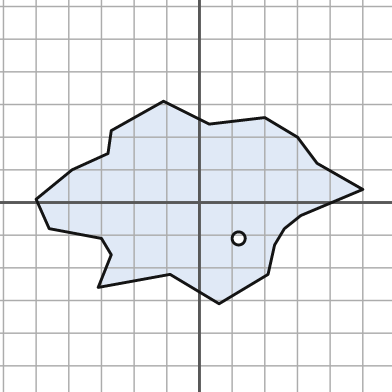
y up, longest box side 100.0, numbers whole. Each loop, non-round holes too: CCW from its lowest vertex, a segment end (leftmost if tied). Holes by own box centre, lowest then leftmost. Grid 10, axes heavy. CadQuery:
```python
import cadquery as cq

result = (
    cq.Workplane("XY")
    .moveTo(6.0, -31.0)
    .lineTo(21.0, -22.0)
    .lineTo(23.0, -13.0)
    .lineTo(26.0, -8.0)
    .lineTo(31.0, -4.0)
    .lineTo(50.0, 4.0)
    .lineTo(36.0, 12.0)
    .lineTo(30.0, 20.0)
    .lineTo(20.0, 26.0)
    .lineTo(3.0, 24.0)
    .lineTo(-11.0, 31.0)
    .lineTo(-27.0, 22.0)
    .lineTo(-28.0, 15.0)
    .lineTo(-39.0, 10.0)
    .lineTo(-50.0, 1.0)
    .lineTo(-46.0, -8.0)
    .lineTo(-30.0, -11.0)
    .lineTo(-27.0, -16.0)
    .lineTo(-31.0, -26.0)
    .lineTo(-9.0, -22.0)
    .close()
    .moveTo(12.0, -11.0)
    .circle(2.0)
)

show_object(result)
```